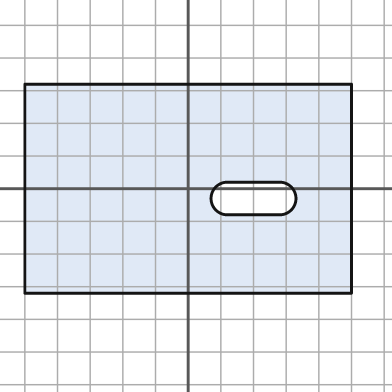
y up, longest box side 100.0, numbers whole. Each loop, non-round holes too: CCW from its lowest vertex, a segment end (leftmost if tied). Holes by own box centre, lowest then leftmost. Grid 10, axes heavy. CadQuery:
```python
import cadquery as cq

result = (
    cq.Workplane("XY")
    .moveTo(-50.0, -32.0)
    .lineTo(50.0, -32.0)
    .lineTo(50.0, 32.0)
    .lineTo(-50.0, 32.0)
    .close()
    .moveTo(12.0, -8.0)
    .lineTo(28.0, -8.0)
    .threePointArc((33.0, -3.0), (28.0, 2.0))
    .lineTo(12.0, 2.0)
    .threePointArc((7.0, -3.0), (12.0, -8.0))
    .close()
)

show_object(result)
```